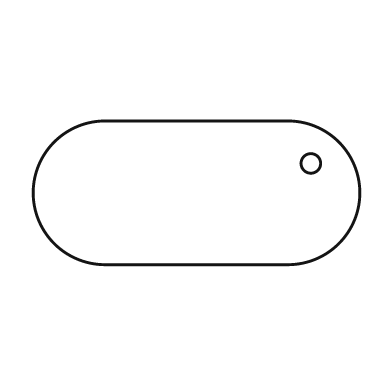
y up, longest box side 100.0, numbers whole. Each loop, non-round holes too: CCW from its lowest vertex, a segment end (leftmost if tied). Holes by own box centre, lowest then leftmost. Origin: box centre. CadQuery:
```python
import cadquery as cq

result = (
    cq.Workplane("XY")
    .moveTo(-28.0, -22.0)
    .lineTo(28.0, -22.0)
    .threePointArc((50.0, 0.0), (28.0, 22.0))
    .lineTo(-28.0, 22.0)
    .threePointArc((-50.0, 0.0), (-28.0, -22.0))
    .close()
    .moveTo(35.0, 9.0)
    .circle(3.0)
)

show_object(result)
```